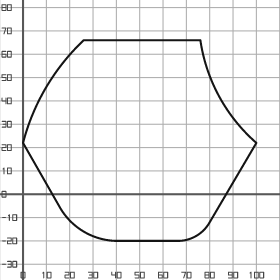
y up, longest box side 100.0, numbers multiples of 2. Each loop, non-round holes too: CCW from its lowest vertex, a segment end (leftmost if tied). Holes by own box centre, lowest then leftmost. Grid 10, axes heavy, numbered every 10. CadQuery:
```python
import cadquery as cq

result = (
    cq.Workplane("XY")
    .moveTo(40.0, -20.0)
    .lineTo(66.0, -20.0)
    .threePointArc((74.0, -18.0), (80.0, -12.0))
    .lineTo(100.0, 22.0)
    .threePointArc((84.0, 42.0), (76.0, 66.0))
    .lineTo(26.0, 66.0)
    .threePointArc((10.0, 46.0), (0.0, 22.0))
    .lineTo(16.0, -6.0)
    .threePointArc((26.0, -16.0), (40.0, -20.0))
    .close()
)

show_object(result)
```